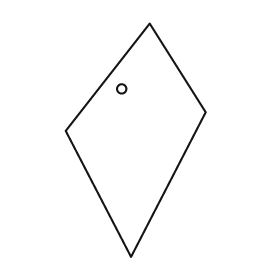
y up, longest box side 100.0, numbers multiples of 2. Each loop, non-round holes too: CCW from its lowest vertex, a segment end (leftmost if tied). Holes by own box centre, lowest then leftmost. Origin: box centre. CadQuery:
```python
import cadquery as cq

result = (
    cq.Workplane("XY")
    .moveTo(-2.0, -50.0)
    .lineTo(30.0, 12.0)
    .lineTo(6.0, 50.0)
    .lineTo(-30.0, 4.0)
    .close()
    .moveTo(-6.0, 22.0)
    .circle(2.0)
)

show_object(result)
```